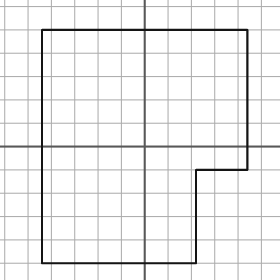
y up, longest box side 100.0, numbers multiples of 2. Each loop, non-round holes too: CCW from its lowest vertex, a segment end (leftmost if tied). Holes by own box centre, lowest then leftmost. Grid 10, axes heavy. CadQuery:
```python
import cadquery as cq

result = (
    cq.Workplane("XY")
    .moveTo(-44.0, -50.0)
    .lineTo(22.0, -50.0)
    .lineTo(22.0, -10.0)
    .lineTo(44.0, -10.0)
    .lineTo(44.0, 50.0)
    .lineTo(-44.0, 50.0)
    .close()
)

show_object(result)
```